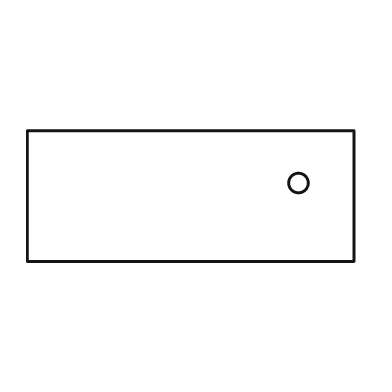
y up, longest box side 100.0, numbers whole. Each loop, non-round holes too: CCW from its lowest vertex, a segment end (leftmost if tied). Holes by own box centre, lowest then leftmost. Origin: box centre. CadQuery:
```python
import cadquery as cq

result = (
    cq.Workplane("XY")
    .moveTo(-50.0, -20.0)
    .lineTo(50.0, -20.0)
    .lineTo(50.0, 20.0)
    .lineTo(-50.0, 20.0)
    .close()
    .moveTo(33.0, 4.0)
    .circle(3.0)
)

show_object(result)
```